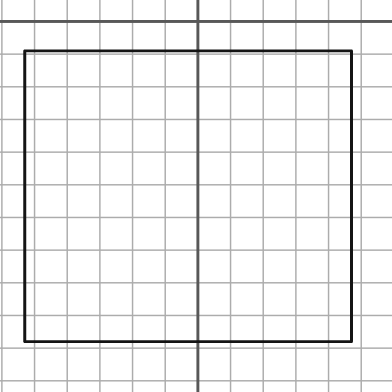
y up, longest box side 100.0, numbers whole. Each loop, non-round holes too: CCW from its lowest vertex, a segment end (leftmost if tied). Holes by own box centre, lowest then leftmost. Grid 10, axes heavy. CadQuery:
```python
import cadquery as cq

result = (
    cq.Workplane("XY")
    .moveTo(-53.0, -98.0)
    .lineTo(47.0, -98.0)
    .lineTo(47.0, -9.0)
    .lineTo(-53.0, -9.0)
    .close()
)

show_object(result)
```